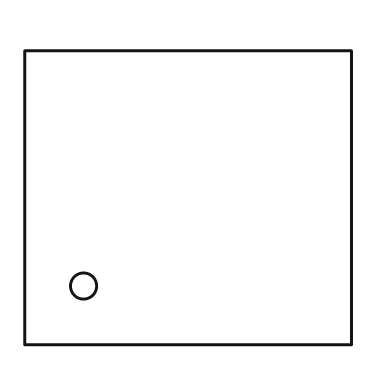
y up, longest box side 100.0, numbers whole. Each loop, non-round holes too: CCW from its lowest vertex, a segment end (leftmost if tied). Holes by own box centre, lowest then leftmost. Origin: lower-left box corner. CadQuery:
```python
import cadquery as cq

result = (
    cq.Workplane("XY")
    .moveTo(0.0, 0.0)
    .lineTo(100.0, 0.0)
    .lineTo(100.0, 90.0)
    .lineTo(0.0, 90.0)
    .close()
    .moveTo(18.0, 18.0)
    .circle(4.0)
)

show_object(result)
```